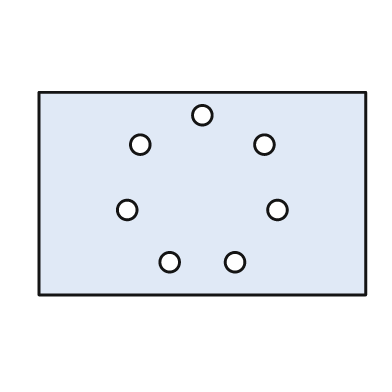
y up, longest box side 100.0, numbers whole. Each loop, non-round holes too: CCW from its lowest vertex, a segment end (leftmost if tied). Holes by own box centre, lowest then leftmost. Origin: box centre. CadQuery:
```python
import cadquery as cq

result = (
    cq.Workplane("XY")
    .moveTo(-50.0, -31.0)
    .lineTo(50.0, -31.0)
    .lineTo(50.0, 31.0)
    .lineTo(-50.0, 31.0)
    .close()
    .moveTo(-10.0, -21.0)
    .circle(3.0)
    .moveTo(10.0, -21.0)
    .circle(3.0)
    .moveTo(-23.0, -5.0)
    .circle(3.0)
    .moveTo(23.0, -5.0)
    .circle(3.0)
    .moveTo(-19.0, 15.0)
    .circle(3.0)
    .moveTo(19.0, 15.0)
    .circle(3.0)
    .moveTo(0.0, 24.0)
    .circle(3.0)
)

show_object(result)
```